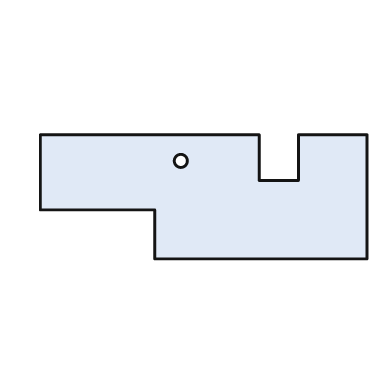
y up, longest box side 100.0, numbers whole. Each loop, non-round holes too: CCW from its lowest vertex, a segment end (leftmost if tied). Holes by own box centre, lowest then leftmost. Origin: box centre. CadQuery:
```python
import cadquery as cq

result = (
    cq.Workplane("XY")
    .moveTo(-15.0, -19.0)
    .lineTo(50.0, -19.0)
    .lineTo(50.0, 19.0)
    .lineTo(29.0, 19.0)
    .lineTo(29.0, 5.0)
    .lineTo(17.0, 5.0)
    .lineTo(17.0, 19.0)
    .lineTo(-50.0, 19.0)
    .lineTo(-50.0, -4.0)
    .lineTo(-15.0, -4.0)
    .close()
    .moveTo(-7.0, 11.0)
    .circle(2.0)
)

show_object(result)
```